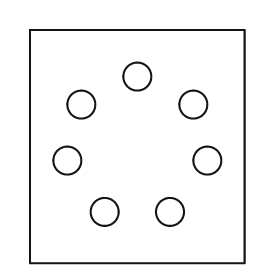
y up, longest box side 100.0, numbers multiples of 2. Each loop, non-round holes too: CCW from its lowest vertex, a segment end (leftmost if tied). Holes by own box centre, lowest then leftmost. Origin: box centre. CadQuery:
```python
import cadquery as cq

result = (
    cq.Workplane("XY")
    .moveTo(-46.0, -50.0)
    .lineTo(46.0, -50.0)
    .lineTo(46.0, 50.0)
    .lineTo(-46.0, 50.0)
    .close()
    .moveTo(-14.0, -28.0)
    .circle(6.0)
    .moveTo(14.0, -28.0)
    .circle(6.0)
    .moveTo(-30.0, -6.0)
    .circle(6.0)
    .moveTo(30.0, -6.0)
    .circle(6.0)
    .moveTo(-24.0, 18.0)
    .circle(6.0)
    .moveTo(24.0, 18.0)
    .circle(6.0)
    .moveTo(0.0, 30.0)
    .circle(6.0)
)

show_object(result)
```